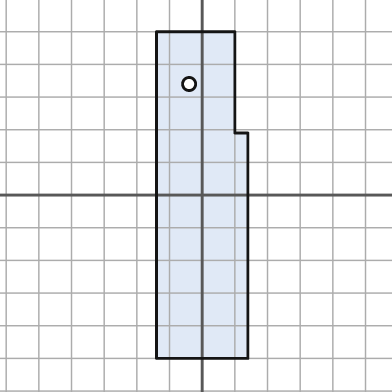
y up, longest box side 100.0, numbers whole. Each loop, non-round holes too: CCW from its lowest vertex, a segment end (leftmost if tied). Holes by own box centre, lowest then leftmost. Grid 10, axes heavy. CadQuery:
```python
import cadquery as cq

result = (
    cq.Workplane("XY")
    .moveTo(-14.0, -50.0)
    .lineTo(14.0, -50.0)
    .lineTo(14.0, 19.0)
    .lineTo(10.0, 19.0)
    .lineTo(10.0, 50.0)
    .lineTo(-14.0, 50.0)
    .close()
    .moveTo(-4.0, 34.0)
    .circle(2.0)
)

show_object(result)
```